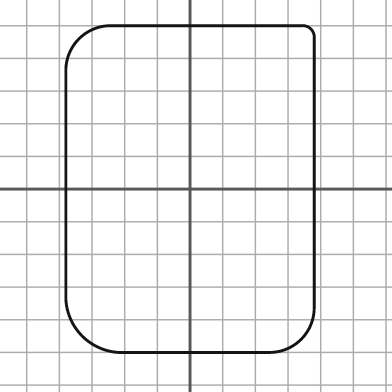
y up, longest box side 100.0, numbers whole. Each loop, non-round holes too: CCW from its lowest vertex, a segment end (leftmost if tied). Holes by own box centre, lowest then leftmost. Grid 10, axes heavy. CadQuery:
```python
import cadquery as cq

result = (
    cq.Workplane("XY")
    .moveTo(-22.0, -50.0)
    .lineTo(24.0, -50.0)
    .threePointArc((34.0, -46.0), (38.0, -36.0))
    .lineTo(38.0, 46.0)
    .threePointArc((37.0, 49.0), (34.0, 50.0))
    .lineTo(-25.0, 50.0)
    .threePointArc((-34.0, 46.0), (-38.0, 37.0))
    .lineTo(-38.0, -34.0)
    .threePointArc((-33.0, -45.0), (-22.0, -50.0))
    .close()
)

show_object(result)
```